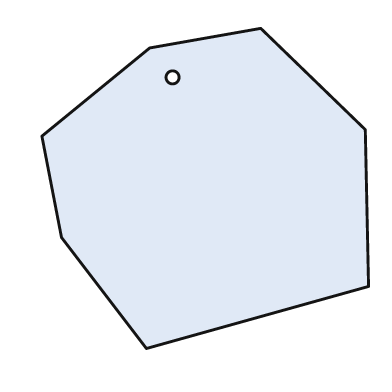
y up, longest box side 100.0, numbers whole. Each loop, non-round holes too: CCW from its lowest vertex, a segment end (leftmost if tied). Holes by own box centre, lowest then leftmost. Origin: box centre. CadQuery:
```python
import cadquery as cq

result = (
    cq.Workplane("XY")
    .moveTo(-18.0, -49.0)
    .lineTo(50.0, -30.0)
    .lineTo(49.0, 18.0)
    .lineTo(17.0, 49.0)
    .lineTo(-17.0, 43.0)
    .lineTo(-50.0, 16.0)
    .lineTo(-44.0, -15.0)
    .close()
    .moveTo(-10.0, 34.0)
    .circle(2.0)
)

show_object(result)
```